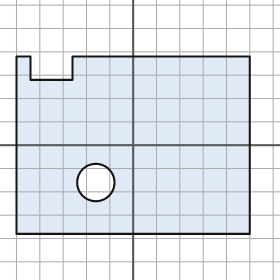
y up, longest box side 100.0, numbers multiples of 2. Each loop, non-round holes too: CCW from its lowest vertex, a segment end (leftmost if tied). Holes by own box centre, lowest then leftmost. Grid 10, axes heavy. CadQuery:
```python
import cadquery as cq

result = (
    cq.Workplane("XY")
    .moveTo(-50.0, -38.0)
    .lineTo(50.0, -38.0)
    .lineTo(50.0, 38.0)
    .lineTo(-26.0, 38.0)
    .lineTo(-26.0, 28.0)
    .lineTo(-44.0, 28.0)
    .lineTo(-44.0, 38.0)
    .lineTo(-50.0, 38.0)
    .close()
    .moveTo(-16.0, -16.0)
    .circle(8.0)
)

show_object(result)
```